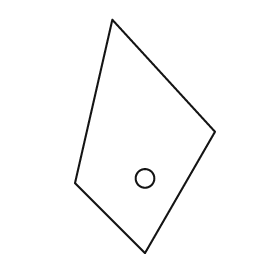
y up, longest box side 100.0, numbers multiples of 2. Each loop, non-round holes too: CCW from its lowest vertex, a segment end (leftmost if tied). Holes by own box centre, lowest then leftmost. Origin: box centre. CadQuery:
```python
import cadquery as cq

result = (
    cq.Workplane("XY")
    .moveTo(0.0, -50.0)
    .lineTo(30.0, 2.0)
    .lineTo(-14.0, 50.0)
    .lineTo(-30.0, -20.0)
    .close()
    .moveTo(0.0, -18.0)
    .circle(4.0)
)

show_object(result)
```